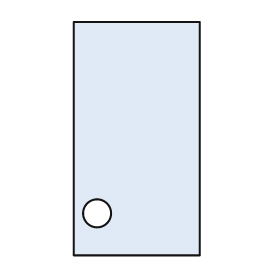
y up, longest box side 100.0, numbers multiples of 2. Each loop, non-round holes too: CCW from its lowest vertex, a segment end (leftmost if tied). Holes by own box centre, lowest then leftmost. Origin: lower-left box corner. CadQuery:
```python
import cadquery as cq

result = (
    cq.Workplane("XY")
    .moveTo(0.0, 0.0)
    .lineTo(54.0, 0.0)
    .lineTo(54.0, 100.0)
    .lineTo(0.0, 100.0)
    .close()
    .moveTo(10.0, 18.0)
    .circle(6.0)
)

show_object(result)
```